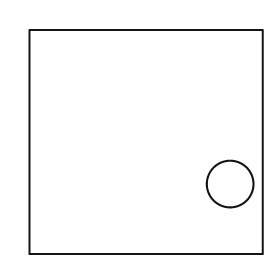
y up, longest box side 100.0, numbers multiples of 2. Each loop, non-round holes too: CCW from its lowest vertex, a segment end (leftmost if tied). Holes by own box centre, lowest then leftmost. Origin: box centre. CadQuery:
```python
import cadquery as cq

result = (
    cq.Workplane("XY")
    .moveTo(-50.0, -48.0)
    .lineTo(50.0, -48.0)
    .lineTo(50.0, 48.0)
    .lineTo(-50.0, 48.0)
    .close()
    .moveTo(36.0, -18.0)
    .circle(10.0)
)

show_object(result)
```